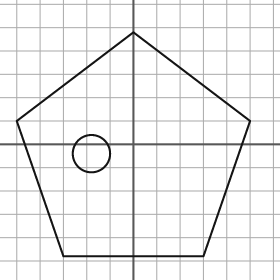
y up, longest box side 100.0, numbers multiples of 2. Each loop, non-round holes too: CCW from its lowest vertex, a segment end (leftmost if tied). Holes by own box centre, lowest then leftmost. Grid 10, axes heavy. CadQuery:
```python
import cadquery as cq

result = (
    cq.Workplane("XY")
    .moveTo(-30.0, -48.0)
    .lineTo(30.0, -48.0)
    .lineTo(50.0, 10.0)
    .lineTo(0.0, 48.0)
    .lineTo(-50.0, 10.0)
    .close()
    .moveTo(-18.0, -4.0)
    .circle(8.0)
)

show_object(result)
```